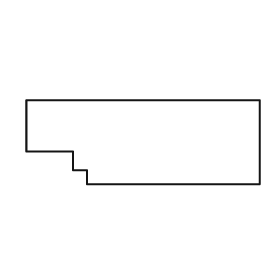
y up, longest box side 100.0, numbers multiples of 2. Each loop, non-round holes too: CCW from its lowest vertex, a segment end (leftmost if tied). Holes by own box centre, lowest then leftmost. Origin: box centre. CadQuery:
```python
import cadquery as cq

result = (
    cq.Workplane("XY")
    .moveTo(-24.0, -18.0)
    .lineTo(50.0, -18.0)
    .lineTo(50.0, 18.0)
    .lineTo(-50.0, 18.0)
    .lineTo(-50.0, -4.0)
    .lineTo(-30.0, -4.0)
    .lineTo(-30.0, -12.0)
    .lineTo(-24.0, -12.0)
    .close()
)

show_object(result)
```